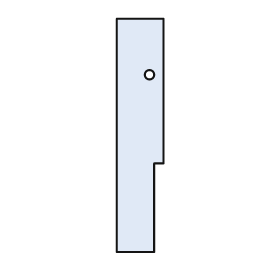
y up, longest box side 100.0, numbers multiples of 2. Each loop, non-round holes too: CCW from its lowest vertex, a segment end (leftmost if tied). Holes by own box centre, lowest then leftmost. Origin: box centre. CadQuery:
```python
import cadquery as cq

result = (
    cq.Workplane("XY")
    .moveTo(-10.0, -50.0)
    .lineTo(6.0, -50.0)
    .lineTo(6.0, -12.0)
    .lineTo(10.0, -12.0)
    .lineTo(10.0, 50.0)
    .lineTo(-10.0, 50.0)
    .close()
    .moveTo(4.0, 26.0)
    .circle(2.0)
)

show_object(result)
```